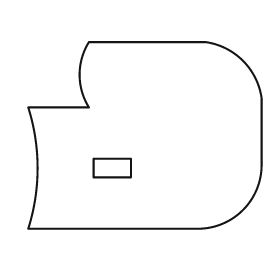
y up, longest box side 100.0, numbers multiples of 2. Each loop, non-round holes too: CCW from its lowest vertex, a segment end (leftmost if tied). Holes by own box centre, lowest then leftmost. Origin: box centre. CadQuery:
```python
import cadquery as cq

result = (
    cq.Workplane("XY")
    .moveTo(-50.0, -40.0)
    .lineTo(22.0, -40.0)
    .threePointArc((42.0, -32.0), (50.0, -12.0))
    .lineTo(50.0, 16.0)
    .threePointArc((42.0, 32.0), (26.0, 40.0))
    .lineTo(-24.0, 40.0)
    .threePointArc((-28.0, 26.0), (-24.0, 12.0))
    .lineTo(-50.0, 12.0)
    .threePointArc((-46.0, -14.0), (-50.0, -40.0))
    .close()
    .moveTo(-22.0, -18.0)
    .lineTo(-6.0, -18.0)
    .lineTo(-6.0, -10.0)
    .lineTo(-22.0, -10.0)
    .close()
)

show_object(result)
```